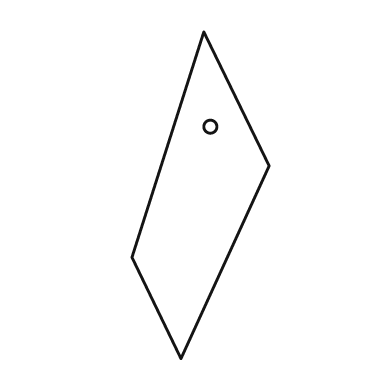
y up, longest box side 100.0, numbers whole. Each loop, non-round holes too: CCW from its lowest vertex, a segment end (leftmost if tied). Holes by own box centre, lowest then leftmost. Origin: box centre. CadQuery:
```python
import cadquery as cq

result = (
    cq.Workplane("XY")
    .moveTo(-6.0, -50.0)
    .lineTo(21.0, 9.0)
    .lineTo(1.0, 50.0)
    .lineTo(-21.0, -19.0)
    .close()
    .moveTo(3.0, 21.0)
    .circle(2.0)
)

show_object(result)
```